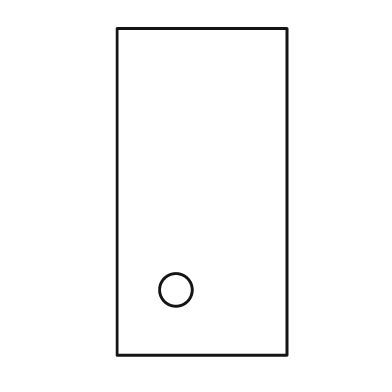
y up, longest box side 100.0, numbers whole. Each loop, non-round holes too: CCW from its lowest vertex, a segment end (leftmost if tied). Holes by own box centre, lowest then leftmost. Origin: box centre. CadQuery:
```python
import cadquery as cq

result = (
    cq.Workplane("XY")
    .moveTo(-26.0, -50.0)
    .lineTo(26.0, -50.0)
    .lineTo(26.0, 50.0)
    .lineTo(-26.0, 50.0)
    .close()
    .moveTo(-8.0, -30.0)
    .circle(5.0)
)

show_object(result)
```